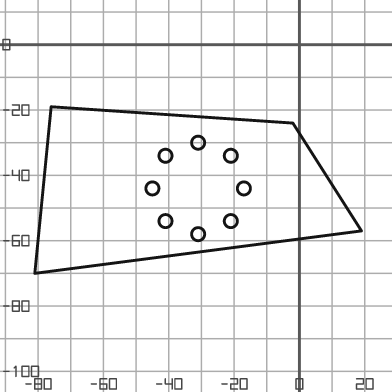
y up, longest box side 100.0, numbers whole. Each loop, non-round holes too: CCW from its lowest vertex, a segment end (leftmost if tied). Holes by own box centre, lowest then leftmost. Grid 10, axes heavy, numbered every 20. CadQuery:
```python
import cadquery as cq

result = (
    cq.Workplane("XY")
    .moveTo(-81.0, -70.0)
    .lineTo(19.0, -57.0)
    .lineTo(-2.0, -24.0)
    .lineTo(-76.0, -19.0)
    .close()
    .moveTo(-31.0, -58.0)
    .circle(2.0)
    .moveTo(-41.0, -54.0)
    .circle(2.0)
    .moveTo(-21.0, -54.0)
    .circle(2.0)
    .moveTo(-45.0, -44.0)
    .circle(2.0)
    .moveTo(-17.0, -44.0)
    .circle(2.0)
    .moveTo(-41.0, -34.0)
    .circle(2.0)
    .moveTo(-21.0, -34.0)
    .circle(2.0)
    .moveTo(-31.0, -30.0)
    .circle(2.0)
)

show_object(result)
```